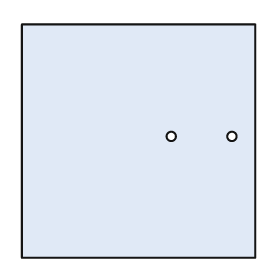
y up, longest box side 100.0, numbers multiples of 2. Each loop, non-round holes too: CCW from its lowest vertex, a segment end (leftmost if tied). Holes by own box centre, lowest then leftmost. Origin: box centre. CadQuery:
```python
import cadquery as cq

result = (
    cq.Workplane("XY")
    .moveTo(-50.0, -50.0)
    .lineTo(50.0, -50.0)
    .lineTo(50.0, 50.0)
    .lineTo(-50.0, 50.0)
    .close()
    .moveTo(14.0, 2.0)
    .circle(2.0)
    .moveTo(40.0, 2.0)
    .circle(2.0)
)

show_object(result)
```